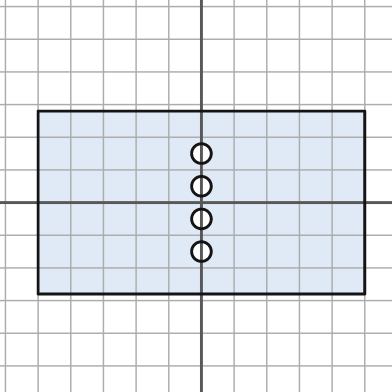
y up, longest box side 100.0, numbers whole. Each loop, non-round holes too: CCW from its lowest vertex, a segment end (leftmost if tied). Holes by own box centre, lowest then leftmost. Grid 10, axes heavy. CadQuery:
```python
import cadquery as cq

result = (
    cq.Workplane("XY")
    .moveTo(-50.0, -28.0)
    .lineTo(50.0, -28.0)
    .lineTo(50.0, 28.0)
    .lineTo(-50.0, 28.0)
    .close()
    .moveTo(0.0, -15.0)
    .circle(3.0)
    .moveTo(0.0, -5.0)
    .circle(3.0)
    .moveTo(0.0, 5.0)
    .circle(3.0)
    .moveTo(0.0, 15.0)
    .circle(3.0)
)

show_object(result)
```